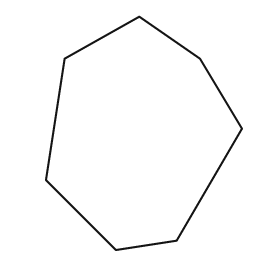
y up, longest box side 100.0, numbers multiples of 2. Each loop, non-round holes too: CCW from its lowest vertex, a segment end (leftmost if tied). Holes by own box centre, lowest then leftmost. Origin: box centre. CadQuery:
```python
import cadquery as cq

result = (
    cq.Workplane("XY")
    .moveTo(-12.0, -50.0)
    .lineTo(14.0, -46.0)
    .lineTo(42.0, 2.0)
    .lineTo(24.0, 32.0)
    .lineTo(-2.0, 50.0)
    .lineTo(-34.0, 32.0)
    .lineTo(-42.0, -20.0)
    .close()
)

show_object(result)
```